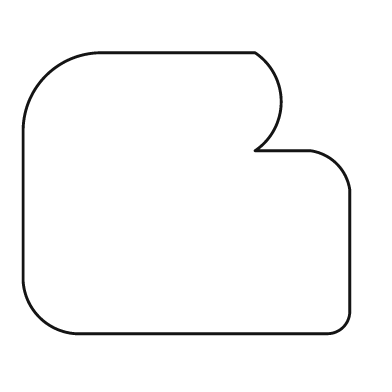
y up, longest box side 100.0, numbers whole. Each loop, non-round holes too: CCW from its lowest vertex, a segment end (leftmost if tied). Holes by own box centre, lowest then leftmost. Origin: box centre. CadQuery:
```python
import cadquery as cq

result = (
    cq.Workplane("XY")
    .moveTo(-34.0, -43.0)
    .lineTo(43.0, -43.0)
    .threePointArc((48.0, -41.0), (50.0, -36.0))
    .lineTo(50.0, 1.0)
    .threePointArc((46.0, 9.0), (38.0, 13.0))
    .lineTo(21.0, 13.0)
    .threePointArc((29.0, 28.0), (21.0, 43.0))
    .lineTo(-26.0, 43.0)
    .threePointArc((-43.0, 36.0), (-50.0, 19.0))
    .lineTo(-50.0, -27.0)
    .threePointArc((-45.0, -38.0), (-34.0, -43.0))
    .close()
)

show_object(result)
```